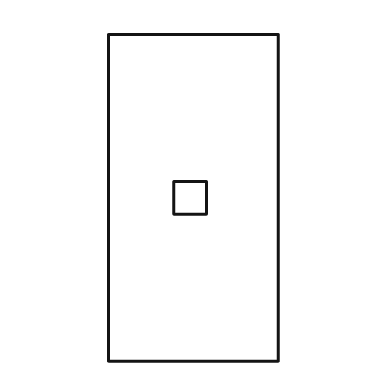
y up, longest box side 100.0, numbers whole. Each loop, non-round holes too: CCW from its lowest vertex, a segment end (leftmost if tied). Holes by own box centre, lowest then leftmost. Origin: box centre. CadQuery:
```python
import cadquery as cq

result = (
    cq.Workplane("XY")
    .moveTo(-26.0, -50.0)
    .lineTo(26.0, -50.0)
    .lineTo(26.0, 50.0)
    .lineTo(-26.0, 50.0)
    .close()
    .moveTo(-6.0, -5.0)
    .lineTo(4.0, -5.0)
    .lineTo(4.0, 5.0)
    .lineTo(-6.0, 5.0)
    .close()
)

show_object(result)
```